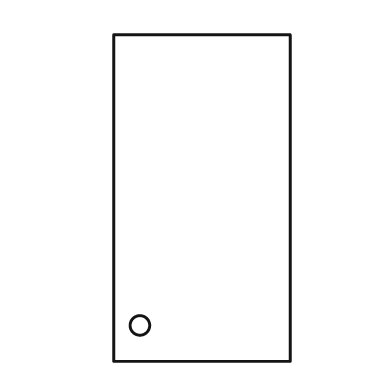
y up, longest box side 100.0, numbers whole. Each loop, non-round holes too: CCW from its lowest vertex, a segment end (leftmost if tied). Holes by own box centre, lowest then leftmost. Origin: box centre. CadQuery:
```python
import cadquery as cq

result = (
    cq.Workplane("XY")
    .moveTo(-27.0, -50.0)
    .lineTo(27.0, -50.0)
    .lineTo(27.0, 50.0)
    .lineTo(-27.0, 50.0)
    .close()
    .moveTo(-19.0, -39.0)
    .circle(3.0)
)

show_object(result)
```